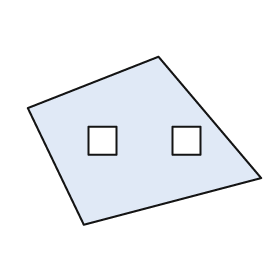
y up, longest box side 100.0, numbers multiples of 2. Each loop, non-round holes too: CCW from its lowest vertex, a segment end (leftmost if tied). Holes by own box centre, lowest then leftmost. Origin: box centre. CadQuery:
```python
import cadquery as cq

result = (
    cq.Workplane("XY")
    .moveTo(-26.0, -36.0)
    .lineTo(50.0, -16.0)
    .lineTo(6.0, 36.0)
    .lineTo(-50.0, 14.0)
    .close()
    .moveTo(-24.0, -6.0)
    .lineTo(-12.0, -6.0)
    .lineTo(-12.0, 6.0)
    .lineTo(-24.0, 6.0)
    .close()
    .moveTo(12.0, -6.0)
    .lineTo(24.0, -6.0)
    .lineTo(24.0, 6.0)
    .lineTo(12.0, 6.0)
    .close()
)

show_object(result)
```